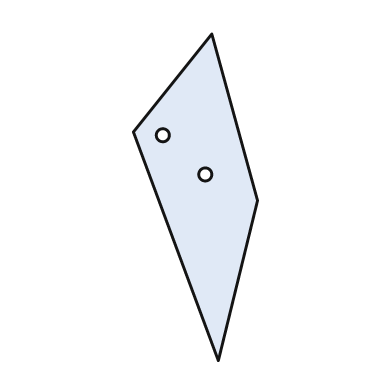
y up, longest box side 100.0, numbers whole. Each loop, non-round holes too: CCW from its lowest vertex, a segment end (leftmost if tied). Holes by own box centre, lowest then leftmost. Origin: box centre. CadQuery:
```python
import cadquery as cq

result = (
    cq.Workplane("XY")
    .moveTo(7.0, -50.0)
    .lineTo(19.0, -1.0)
    .lineTo(5.0, 50.0)
    .lineTo(-19.0, 20.0)
    .close()
    .moveTo(3.0, 7.0)
    .circle(2.0)
    .moveTo(-10.0, 19.0)
    .circle(2.0)
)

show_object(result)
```